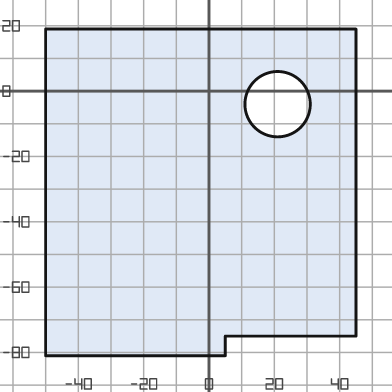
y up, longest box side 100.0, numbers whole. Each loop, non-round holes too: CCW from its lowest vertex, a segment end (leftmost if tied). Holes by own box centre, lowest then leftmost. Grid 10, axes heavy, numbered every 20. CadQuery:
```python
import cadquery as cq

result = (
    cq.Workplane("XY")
    .moveTo(-50.0, -81.0)
    .lineTo(5.0, -81.0)
    .lineTo(5.0, -75.0)
    .lineTo(45.0, -75.0)
    .lineTo(45.0, 19.0)
    .lineTo(-50.0, 19.0)
    .close()
    .moveTo(21.0, -4.0)
    .circle(10.0)
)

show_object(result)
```